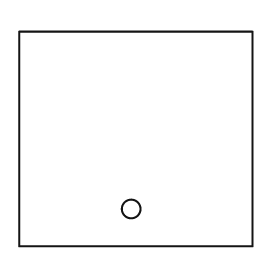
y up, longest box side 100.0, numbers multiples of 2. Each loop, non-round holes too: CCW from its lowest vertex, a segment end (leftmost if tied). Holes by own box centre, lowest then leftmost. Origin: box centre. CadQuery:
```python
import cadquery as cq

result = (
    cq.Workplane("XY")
    .moveTo(-50.0, -46.0)
    .lineTo(50.0, -46.0)
    .lineTo(50.0, 46.0)
    .lineTo(-50.0, 46.0)
    .close()
    .moveTo(-2.0, -30.0)
    .circle(4.0)
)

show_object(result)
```